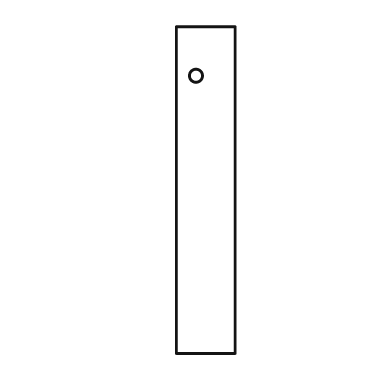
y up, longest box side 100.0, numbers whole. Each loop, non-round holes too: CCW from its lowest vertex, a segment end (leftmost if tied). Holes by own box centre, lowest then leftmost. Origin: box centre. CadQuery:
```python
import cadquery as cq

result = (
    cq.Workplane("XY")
    .moveTo(-9.0, -50.0)
    .lineTo(9.0, -50.0)
    .lineTo(9.0, 50.0)
    .lineTo(-9.0, 50.0)
    .close()
    .moveTo(-3.0, 35.0)
    .circle(2.0)
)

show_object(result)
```